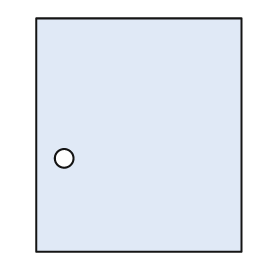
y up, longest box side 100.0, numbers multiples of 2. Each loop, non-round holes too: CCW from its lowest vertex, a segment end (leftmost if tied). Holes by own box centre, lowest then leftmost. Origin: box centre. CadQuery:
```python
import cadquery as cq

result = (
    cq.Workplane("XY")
    .moveTo(-44.0, -50.0)
    .lineTo(44.0, -50.0)
    .lineTo(44.0, 50.0)
    .lineTo(-44.0, 50.0)
    .close()
    .moveTo(-32.0, -10.0)
    .circle(4.0)
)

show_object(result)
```